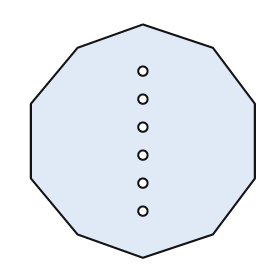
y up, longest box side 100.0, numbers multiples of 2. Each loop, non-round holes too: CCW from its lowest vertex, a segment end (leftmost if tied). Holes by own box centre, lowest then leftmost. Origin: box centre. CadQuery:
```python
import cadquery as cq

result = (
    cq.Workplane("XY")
    .moveTo(0.0, -50.0)
    .lineTo(30.0, -40.0)
    .lineTo(48.0, -16.0)
    .lineTo(48.0, 16.0)
    .lineTo(30.0, 40.0)
    .lineTo(0.0, 50.0)
    .lineTo(-28.0, 40.0)
    .lineTo(-48.0, 16.0)
    .lineTo(-48.0, -16.0)
    .lineTo(-28.0, -40.0)
    .close()
    .moveTo(0.0, -30.0)
    .circle(2.0)
    .moveTo(0.0, -18.0)
    .circle(2.0)
    .moveTo(0.0, -6.0)
    .circle(2.0)
    .moveTo(0.0, 6.0)
    .circle(2.0)
    .moveTo(0.0, 18.0)
    .circle(2.0)
    .moveTo(0.0, 30.0)
    .circle(2.0)
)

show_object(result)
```